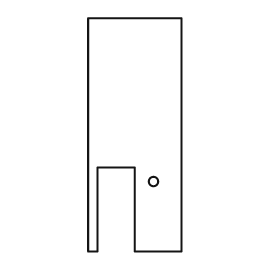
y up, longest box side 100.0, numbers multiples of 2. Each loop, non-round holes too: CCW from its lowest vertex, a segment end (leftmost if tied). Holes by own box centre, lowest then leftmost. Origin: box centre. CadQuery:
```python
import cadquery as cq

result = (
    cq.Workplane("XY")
    .moveTo(-20.0, -50.0)
    .lineTo(-16.0, -50.0)
    .lineTo(-16.0, -14.0)
    .lineTo(0.0, -14.0)
    .lineTo(0.0, -50.0)
    .lineTo(20.0, -50.0)
    .lineTo(20.0, 50.0)
    .lineTo(-20.0, 50.0)
    .close()
    .moveTo(8.0, -20.0)
    .circle(2.0)
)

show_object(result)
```